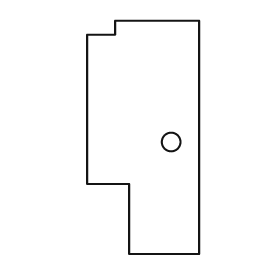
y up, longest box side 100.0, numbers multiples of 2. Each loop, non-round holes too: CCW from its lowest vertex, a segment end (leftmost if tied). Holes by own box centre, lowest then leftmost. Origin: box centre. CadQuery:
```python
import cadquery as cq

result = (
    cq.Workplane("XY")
    .moveTo(-6.0, -50.0)
    .lineTo(24.0, -50.0)
    .lineTo(24.0, 50.0)
    .lineTo(-12.0, 50.0)
    .lineTo(-12.0, 44.0)
    .lineTo(-24.0, 44.0)
    .lineTo(-24.0, -20.0)
    .lineTo(-6.0, -20.0)
    .close()
    .moveTo(12.0, -2.0)
    .circle(4.0)
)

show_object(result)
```